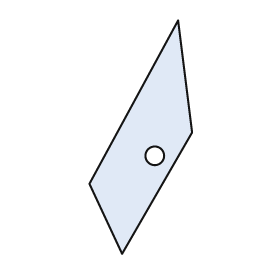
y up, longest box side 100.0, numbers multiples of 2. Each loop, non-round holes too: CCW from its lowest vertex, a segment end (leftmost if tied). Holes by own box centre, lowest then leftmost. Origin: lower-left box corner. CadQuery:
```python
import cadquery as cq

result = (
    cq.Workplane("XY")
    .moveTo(14.0, 0.0)
    .lineTo(44.0, 52.0)
    .lineTo(38.0, 100.0)
    .lineTo(0.0, 30.0)
    .close()
    .moveTo(28.0, 42.0)
    .circle(4.0)
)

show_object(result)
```